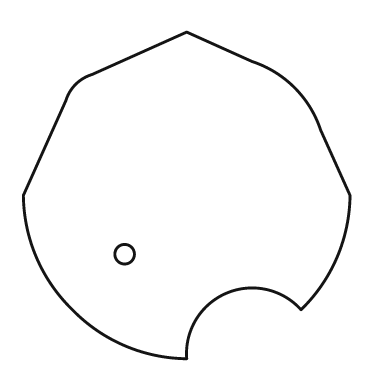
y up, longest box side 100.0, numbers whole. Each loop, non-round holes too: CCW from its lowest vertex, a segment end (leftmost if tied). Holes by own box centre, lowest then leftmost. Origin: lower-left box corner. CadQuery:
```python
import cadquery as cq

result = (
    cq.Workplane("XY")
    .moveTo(50.0, 0.0)
    .threePointArc((62.0, 20.0), (85.0, 15.0))
    .threePointArc((96.0, 31.0), (100.0, 50.0))
    .lineTo(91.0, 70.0)
    .threePointArc((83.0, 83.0), (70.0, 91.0))
    .lineTo(50.0, 100.0)
    .lineTo(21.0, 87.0)
    .threePointArc((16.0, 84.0), (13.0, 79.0))
    .lineTo(0.0, 50.0)
    .threePointArc((4.0, 31.0), (15.0, 15.0))
    .threePointArc((31.0, 4.0), (50.0, 0.0))
    .close()
    .moveTo(31.0, 32.0)
    .circle(3.0)
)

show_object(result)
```